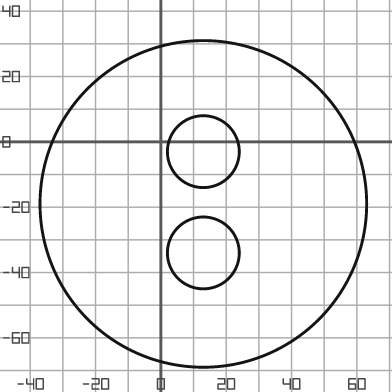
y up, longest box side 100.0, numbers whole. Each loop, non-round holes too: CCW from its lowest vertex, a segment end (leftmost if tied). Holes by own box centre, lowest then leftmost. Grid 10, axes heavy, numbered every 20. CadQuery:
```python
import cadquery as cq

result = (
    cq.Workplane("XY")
    .moveTo(13.0, -19.0)
    .circle(50.0)
    .moveTo(13.0, -34.0)
    .circle(11.0)
    .moveTo(13.0, -3.0)
    .circle(11.0)
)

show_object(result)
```